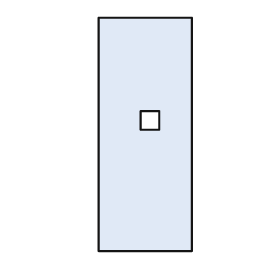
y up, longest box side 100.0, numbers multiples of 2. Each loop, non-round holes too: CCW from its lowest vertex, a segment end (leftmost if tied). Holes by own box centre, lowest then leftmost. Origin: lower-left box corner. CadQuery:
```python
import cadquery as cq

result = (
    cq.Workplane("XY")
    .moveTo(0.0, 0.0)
    .lineTo(40.0, 0.0)
    .lineTo(40.0, 100.0)
    .lineTo(0.0, 100.0)
    .close()
    .moveTo(18.0, 52.0)
    .lineTo(26.0, 52.0)
    .lineTo(26.0, 60.0)
    .lineTo(18.0, 60.0)
    .close()
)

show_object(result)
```